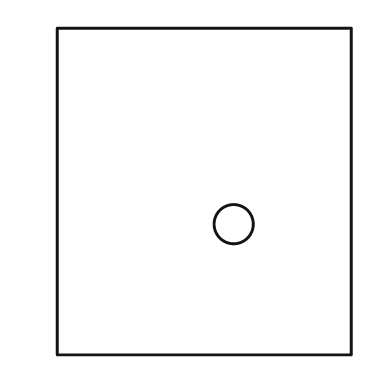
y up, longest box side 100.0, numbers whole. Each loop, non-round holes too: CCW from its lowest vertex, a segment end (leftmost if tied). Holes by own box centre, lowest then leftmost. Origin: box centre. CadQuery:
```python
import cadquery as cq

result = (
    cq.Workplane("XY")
    .moveTo(-45.0, -50.0)
    .lineTo(45.0, -50.0)
    .lineTo(45.0, 50.0)
    .lineTo(-45.0, 50.0)
    .close()
    .moveTo(9.0, -10.0)
    .circle(6.0)
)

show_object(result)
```